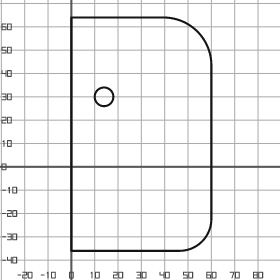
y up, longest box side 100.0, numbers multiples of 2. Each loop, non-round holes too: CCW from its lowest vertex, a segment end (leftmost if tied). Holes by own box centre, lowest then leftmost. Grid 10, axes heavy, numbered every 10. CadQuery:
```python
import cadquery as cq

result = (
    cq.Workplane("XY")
    .moveTo(0.0, -36.0)
    .lineTo(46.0, -36.0)
    .threePointArc((56.0, -32.0), (60.0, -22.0))
    .lineTo(60.0, 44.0)
    .threePointArc((54.0, 58.0), (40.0, 64.0))
    .lineTo(0.0, 64.0)
    .close()
    .moveTo(14.0, 30.0)
    .circle(4.0)
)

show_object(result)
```